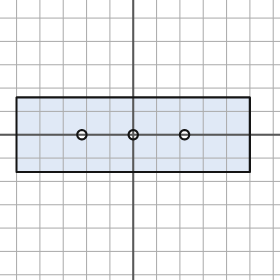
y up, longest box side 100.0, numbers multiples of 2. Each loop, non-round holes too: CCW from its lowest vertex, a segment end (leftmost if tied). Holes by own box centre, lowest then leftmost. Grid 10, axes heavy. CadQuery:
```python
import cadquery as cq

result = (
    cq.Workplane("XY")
    .moveTo(-50.0, -16.0)
    .lineTo(50.0, -16.0)
    .lineTo(50.0, 16.0)
    .lineTo(-50.0, 16.0)
    .close()
    .moveTo(-22.0, 0.0)
    .circle(2.0)
    .moveTo(0.0, 0.0)
    .circle(2.0)
    .moveTo(22.0, 0.0)
    .circle(2.0)
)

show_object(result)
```